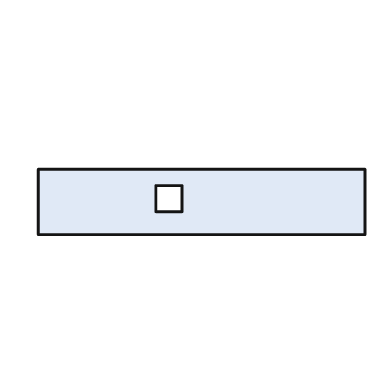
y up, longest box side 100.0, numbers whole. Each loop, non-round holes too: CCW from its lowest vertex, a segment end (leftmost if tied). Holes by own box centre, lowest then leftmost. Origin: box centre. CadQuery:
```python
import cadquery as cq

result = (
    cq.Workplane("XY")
    .moveTo(-50.0, -10.0)
    .lineTo(50.0, -10.0)
    .lineTo(50.0, 10.0)
    .lineTo(-50.0, 10.0)
    .close()
    .moveTo(-14.0, -3.0)
    .lineTo(-6.0, -3.0)
    .lineTo(-6.0, 5.0)
    .lineTo(-14.0, 5.0)
    .close()
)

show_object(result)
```